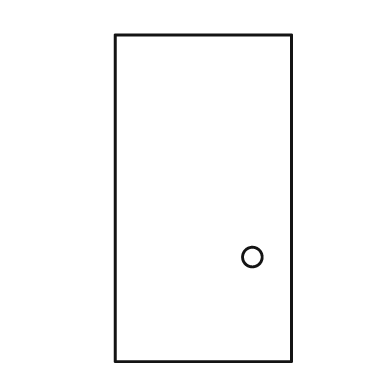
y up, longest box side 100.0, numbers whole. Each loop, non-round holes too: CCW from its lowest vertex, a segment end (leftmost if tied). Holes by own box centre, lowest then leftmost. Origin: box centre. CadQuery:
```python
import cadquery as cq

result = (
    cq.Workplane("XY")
    .moveTo(-27.0, -50.0)
    .lineTo(27.0, -50.0)
    .lineTo(27.0, 50.0)
    .lineTo(-27.0, 50.0)
    .close()
    .moveTo(15.0, -18.0)
    .circle(3.0)
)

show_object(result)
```